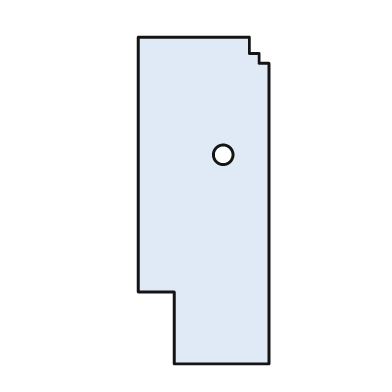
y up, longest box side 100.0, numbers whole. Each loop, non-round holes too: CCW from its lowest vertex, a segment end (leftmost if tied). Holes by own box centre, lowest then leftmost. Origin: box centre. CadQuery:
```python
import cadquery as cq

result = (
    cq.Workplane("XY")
    .moveTo(-9.0, -50.0)
    .lineTo(20.0, -50.0)
    .lineTo(20.0, 42.0)
    .lineTo(17.0, 42.0)
    .lineTo(17.0, 45.0)
    .lineTo(14.0, 45.0)
    .lineTo(14.0, 50.0)
    .lineTo(-20.0, 50.0)
    .lineTo(-20.0, -28.0)
    .lineTo(-9.0, -28.0)
    .close()
    .moveTo(6.0, 14.0)
    .circle(3.0)
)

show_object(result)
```